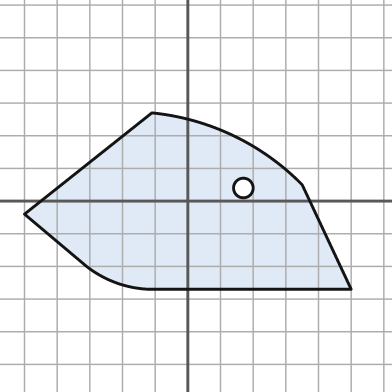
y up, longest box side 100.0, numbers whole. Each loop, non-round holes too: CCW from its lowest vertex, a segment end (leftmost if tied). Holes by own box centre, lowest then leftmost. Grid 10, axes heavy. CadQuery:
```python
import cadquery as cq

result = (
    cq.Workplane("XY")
    .moveTo(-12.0, -27.0)
    .lineTo(50.0, -27.0)
    .lineTo(35.0, 5.0)
    .threePointArc((14.0, 20.0), (-11.0, 27.0))
    .lineTo(-50.0, -4.0)
    .lineTo(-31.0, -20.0)
    .threePointArc((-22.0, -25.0), (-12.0, -27.0))
    .close()
    .moveTo(17.0, 4.0)
    .circle(3.0)
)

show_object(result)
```